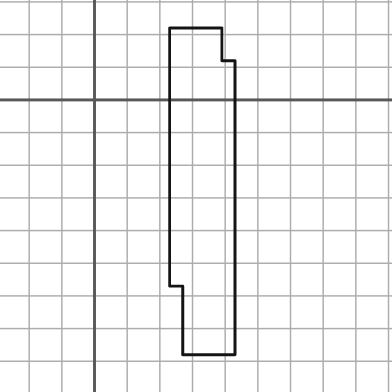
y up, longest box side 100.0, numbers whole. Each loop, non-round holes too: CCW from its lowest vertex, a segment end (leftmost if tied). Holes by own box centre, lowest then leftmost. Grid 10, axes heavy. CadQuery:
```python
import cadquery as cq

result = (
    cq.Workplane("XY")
    .moveTo(27.0, -78.0)
    .lineTo(43.0, -78.0)
    .lineTo(43.0, 12.0)
    .lineTo(39.0, 12.0)
    .lineTo(39.0, 22.0)
    .lineTo(23.0, 22.0)
    .lineTo(23.0, -57.0)
    .lineTo(27.0, -57.0)
    .close()
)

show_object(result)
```